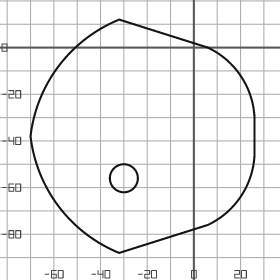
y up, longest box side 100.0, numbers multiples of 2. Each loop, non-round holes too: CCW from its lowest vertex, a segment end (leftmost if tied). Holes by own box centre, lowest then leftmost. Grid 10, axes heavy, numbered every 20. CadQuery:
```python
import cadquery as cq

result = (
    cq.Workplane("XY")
    .moveTo(-32.0, -88.0)
    .lineTo(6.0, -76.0)
    .threePointArc((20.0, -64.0), (26.0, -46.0))
    .lineTo(26.0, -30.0)
    .threePointArc((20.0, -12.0), (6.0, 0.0))
    .lineTo(-32.0, 12.0)
    .threePointArc((-58.0, -8.0), (-70.0, -38.0))
    .threePointArc((-58.0, -68.0), (-32.0, -88.0))
    .close()
    .moveTo(-30.0, -56.0)
    .circle(6.0)
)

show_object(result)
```